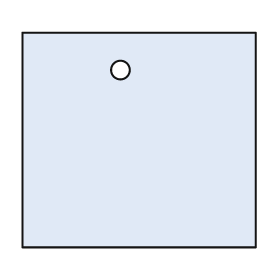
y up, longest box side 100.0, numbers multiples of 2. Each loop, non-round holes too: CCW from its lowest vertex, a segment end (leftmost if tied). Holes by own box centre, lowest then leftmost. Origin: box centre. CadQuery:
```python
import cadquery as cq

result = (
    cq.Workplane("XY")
    .moveTo(-50.0, -46.0)
    .lineTo(50.0, -46.0)
    .lineTo(50.0, 46.0)
    .lineTo(-50.0, 46.0)
    .close()
    .moveTo(-8.0, 30.0)
    .circle(4.0)
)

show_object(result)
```